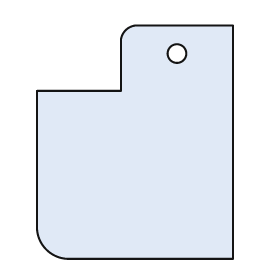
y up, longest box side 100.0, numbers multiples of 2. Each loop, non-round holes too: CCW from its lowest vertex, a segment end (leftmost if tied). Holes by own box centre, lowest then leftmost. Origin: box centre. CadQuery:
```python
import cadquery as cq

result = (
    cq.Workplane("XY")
    .moveTo(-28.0, -50.0)
    .lineTo(42.0, -50.0)
    .lineTo(42.0, 50.0)
    .lineTo(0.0, 50.0)
    .threePointArc((-4.0, 48.0), (-6.0, 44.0))
    .lineTo(-6.0, 22.0)
    .lineTo(-42.0, 22.0)
    .lineTo(-42.0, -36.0)
    .threePointArc((-38.0, -46.0), (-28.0, -50.0))
    .close()
    .moveTo(18.0, 38.0)
    .circle(4.0)
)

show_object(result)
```